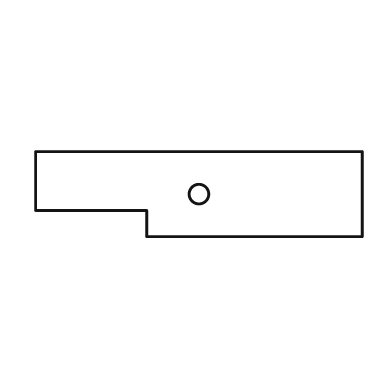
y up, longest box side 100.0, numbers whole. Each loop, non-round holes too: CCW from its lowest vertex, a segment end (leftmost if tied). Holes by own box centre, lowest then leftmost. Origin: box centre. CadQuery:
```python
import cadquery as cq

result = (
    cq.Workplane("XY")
    .moveTo(-16.0, -13.0)
    .lineTo(50.0, -13.0)
    .lineTo(50.0, 13.0)
    .lineTo(-50.0, 13.0)
    .lineTo(-50.0, -5.0)
    .lineTo(-16.0, -5.0)
    .close()
    .moveTo(0.0, 0.0)
    .circle(3.0)
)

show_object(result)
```